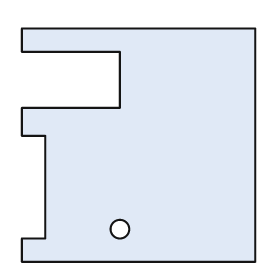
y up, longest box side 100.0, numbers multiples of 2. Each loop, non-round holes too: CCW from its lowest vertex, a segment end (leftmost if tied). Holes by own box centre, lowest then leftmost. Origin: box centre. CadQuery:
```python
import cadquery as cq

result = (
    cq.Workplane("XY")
    .moveTo(-50.0, -50.0)
    .lineTo(50.0, -50.0)
    .lineTo(50.0, 50.0)
    .lineTo(-50.0, 50.0)
    .lineTo(-50.0, 40.0)
    .lineTo(-8.0, 40.0)
    .lineTo(-8.0, 16.0)
    .lineTo(-50.0, 16.0)
    .lineTo(-50.0, 4.0)
    .lineTo(-40.0, 4.0)
    .lineTo(-40.0, -40.0)
    .lineTo(-50.0, -40.0)
    .close()
    .moveTo(-8.0, -36.0)
    .circle(4.0)
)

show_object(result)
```